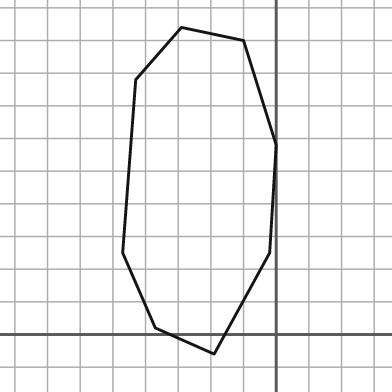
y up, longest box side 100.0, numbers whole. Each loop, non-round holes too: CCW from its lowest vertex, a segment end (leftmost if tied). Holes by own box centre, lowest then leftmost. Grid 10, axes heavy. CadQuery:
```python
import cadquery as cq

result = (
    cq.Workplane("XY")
    .moveTo(-19.0, -6.0)
    .lineTo(-2.0, 25.0)
    .lineTo(0.0, 58.0)
    .lineTo(-10.0, 90.0)
    .lineTo(-29.0, 94.0)
    .lineTo(-43.0, 78.0)
    .lineTo(-47.0, 25.0)
    .lineTo(-37.0, 2.0)
    .close()
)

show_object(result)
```